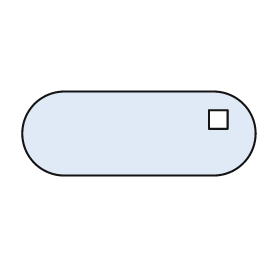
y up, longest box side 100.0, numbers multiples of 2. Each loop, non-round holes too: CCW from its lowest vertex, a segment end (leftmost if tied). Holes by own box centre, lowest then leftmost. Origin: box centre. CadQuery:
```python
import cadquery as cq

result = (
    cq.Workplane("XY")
    .moveTo(-32.0, -18.0)
    .lineTo(32.0, -18.0)
    .threePointArc((50.0, 0.0), (32.0, 18.0))
    .lineTo(-32.0, 18.0)
    .threePointArc((-50.0, 0.0), (-32.0, -18.0))
    .close()
    .moveTo(30.0, 2.0)
    .lineTo(38.0, 2.0)
    .lineTo(38.0, 10.0)
    .lineTo(30.0, 10.0)
    .close()
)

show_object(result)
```